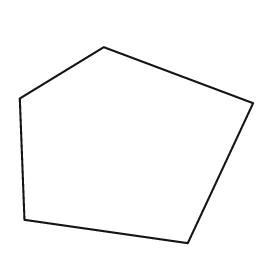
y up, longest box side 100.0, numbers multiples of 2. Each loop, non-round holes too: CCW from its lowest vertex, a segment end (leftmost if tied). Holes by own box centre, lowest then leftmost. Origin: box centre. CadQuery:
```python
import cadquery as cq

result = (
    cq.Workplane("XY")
    .moveTo(22.0, -42.0)
    .lineTo(50.0, 18.0)
    .lineTo(-14.0, 42.0)
    .lineTo(-50.0, 20.0)
    .lineTo(-48.0, -32.0)
    .close()
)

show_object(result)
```